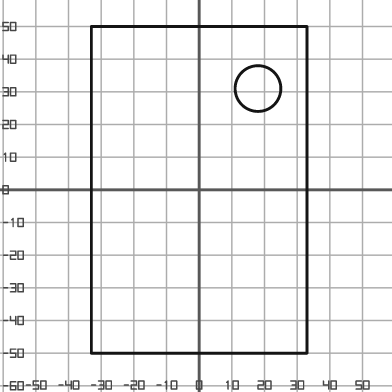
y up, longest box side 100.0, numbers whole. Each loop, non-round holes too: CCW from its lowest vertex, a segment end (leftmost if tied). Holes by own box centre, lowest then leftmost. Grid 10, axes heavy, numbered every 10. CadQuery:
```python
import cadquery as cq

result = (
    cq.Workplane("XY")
    .moveTo(-33.0, -50.0)
    .lineTo(33.0, -50.0)
    .lineTo(33.0, 50.0)
    .lineTo(-33.0, 50.0)
    .close()
    .moveTo(18.0, 31.0)
    .circle(7.0)
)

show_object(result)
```